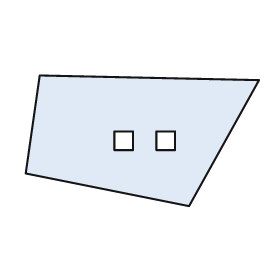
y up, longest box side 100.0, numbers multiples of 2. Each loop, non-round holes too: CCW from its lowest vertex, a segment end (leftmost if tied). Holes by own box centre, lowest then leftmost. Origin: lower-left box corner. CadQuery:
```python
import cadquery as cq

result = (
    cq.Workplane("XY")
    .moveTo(70.0, 0.0)
    .lineTo(100.0, 54.0)
    .lineTo(6.0, 56.0)
    .lineTo(0.0, 14.0)
    .close()
    .moveTo(38.0, 24.0)
    .lineTo(46.0, 24.0)
    .lineTo(46.0, 32.0)
    .lineTo(38.0, 32.0)
    .close()
    .moveTo(56.0, 24.0)
    .lineTo(64.0, 24.0)
    .lineTo(64.0, 32.0)
    .lineTo(56.0, 32.0)
    .close()
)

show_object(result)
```